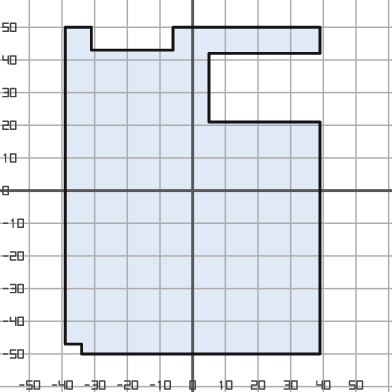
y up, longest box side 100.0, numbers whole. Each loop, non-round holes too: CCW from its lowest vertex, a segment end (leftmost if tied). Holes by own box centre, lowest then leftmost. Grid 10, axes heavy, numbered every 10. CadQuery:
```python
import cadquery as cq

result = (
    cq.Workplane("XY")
    .moveTo(-34.0, -50.0)
    .lineTo(39.0, -50.0)
    .lineTo(39.0, 21.0)
    .lineTo(5.0, 21.0)
    .lineTo(5.0, 42.0)
    .lineTo(39.0, 42.0)
    .lineTo(39.0, 50.0)
    .lineTo(-6.0, 50.0)
    .lineTo(-6.0, 43.0)
    .lineTo(-31.0, 43.0)
    .lineTo(-31.0, 50.0)
    .lineTo(-39.0, 50.0)
    .lineTo(-39.0, -47.0)
    .lineTo(-34.0, -47.0)
    .close()
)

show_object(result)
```